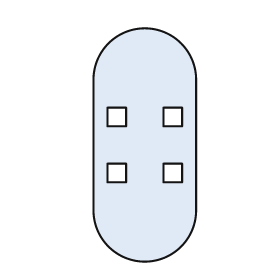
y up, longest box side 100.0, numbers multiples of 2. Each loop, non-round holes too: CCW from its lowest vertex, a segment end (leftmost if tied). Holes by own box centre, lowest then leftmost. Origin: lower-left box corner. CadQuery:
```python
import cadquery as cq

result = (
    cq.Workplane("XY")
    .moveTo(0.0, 22.0)
    .threePointArc((22.0, 0.0), (44.0, 22.0))
    .lineTo(44.0, 78.0)
    .threePointArc((22.0, 100.0), (0.0, 78.0))
    .close()
    .moveTo(6.0, 34.0)
    .lineTo(14.0, 34.0)
    .lineTo(14.0, 42.0)
    .lineTo(6.0, 42.0)
    .close()
    .moveTo(30.0, 34.0)
    .lineTo(38.0, 34.0)
    .lineTo(38.0, 42.0)
    .lineTo(30.0, 42.0)
    .close()
    .moveTo(6.0, 58.0)
    .lineTo(14.0, 58.0)
    .lineTo(14.0, 66.0)
    .lineTo(6.0, 66.0)
    .close()
    .moveTo(30.0, 58.0)
    .lineTo(38.0, 58.0)
    .lineTo(38.0, 66.0)
    .lineTo(30.0, 66.0)
    .close()
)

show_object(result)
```